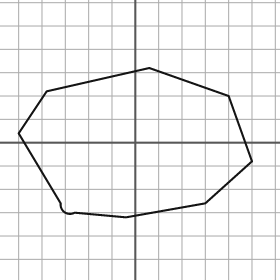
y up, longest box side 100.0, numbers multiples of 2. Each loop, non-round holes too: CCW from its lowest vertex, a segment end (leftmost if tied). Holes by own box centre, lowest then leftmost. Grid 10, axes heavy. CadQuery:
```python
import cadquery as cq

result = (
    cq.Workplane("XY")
    .moveTo(-4.0, -32.0)
    .lineTo(30.0, -26.0)
    .lineTo(50.0, -8.0)
    .lineTo(40.0, 20.0)
    .lineTo(6.0, 32.0)
    .lineTo(-38.0, 22.0)
    .lineTo(-50.0, 4.0)
    .lineTo(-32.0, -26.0)
    .threePointArc((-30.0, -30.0), (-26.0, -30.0))
    .close()
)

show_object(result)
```